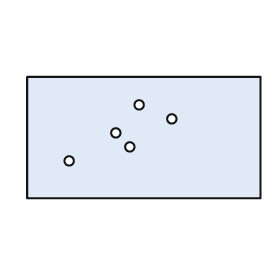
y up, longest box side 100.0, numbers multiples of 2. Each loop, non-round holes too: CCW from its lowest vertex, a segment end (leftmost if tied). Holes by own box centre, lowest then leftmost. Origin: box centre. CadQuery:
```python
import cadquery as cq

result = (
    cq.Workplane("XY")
    .moveTo(-50.0, -26.0)
    .lineTo(50.0, -26.0)
    .lineTo(50.0, 26.0)
    .lineTo(-50.0, 26.0)
    .close()
    .moveTo(-32.0, -10.0)
    .circle(2.0)
    .moveTo(-6.0, -4.0)
    .circle(2.0)
    .moveTo(-12.0, 2.0)
    .circle(2.0)
    .moveTo(12.0, 8.0)
    .circle(2.0)
    .moveTo(-2.0, 14.0)
    .circle(2.0)
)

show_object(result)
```